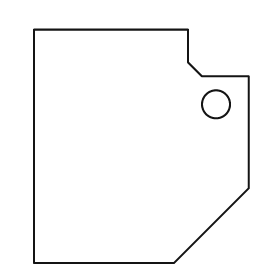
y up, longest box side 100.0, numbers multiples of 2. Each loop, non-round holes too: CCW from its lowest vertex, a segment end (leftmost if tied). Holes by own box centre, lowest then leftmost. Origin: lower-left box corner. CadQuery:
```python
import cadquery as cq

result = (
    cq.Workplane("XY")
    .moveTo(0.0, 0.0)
    .lineTo(60.0, 0.0)
    .lineTo(92.0, 32.0)
    .lineTo(92.0, 80.0)
    .lineTo(72.0, 80.0)
    .lineTo(66.0, 86.0)
    .lineTo(66.0, 100.0)
    .lineTo(0.0, 100.0)
    .close()
    .moveTo(78.0, 68.0)
    .circle(6.0)
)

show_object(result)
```